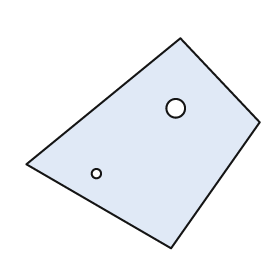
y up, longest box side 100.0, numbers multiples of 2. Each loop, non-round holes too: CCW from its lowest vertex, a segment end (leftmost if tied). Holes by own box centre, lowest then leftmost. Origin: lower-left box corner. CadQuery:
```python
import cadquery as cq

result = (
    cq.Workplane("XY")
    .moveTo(62.0, 0.0)
    .lineTo(100.0, 54.0)
    .lineTo(66.0, 90.0)
    .lineTo(0.0, 36.0)
    .close()
    .moveTo(30.0, 32.0)
    .circle(2.0)
    .moveTo(64.0, 60.0)
    .circle(4.0)
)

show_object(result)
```